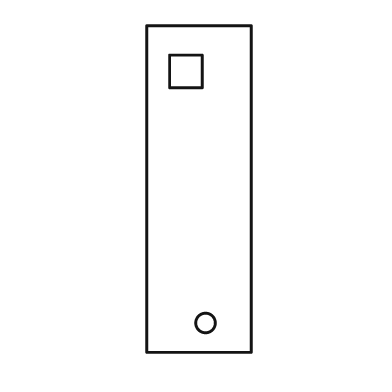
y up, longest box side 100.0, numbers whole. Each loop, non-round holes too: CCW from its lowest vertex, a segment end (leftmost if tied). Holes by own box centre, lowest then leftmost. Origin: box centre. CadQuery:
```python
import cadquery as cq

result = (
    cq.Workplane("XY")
    .moveTo(-16.0, -50.0)
    .lineTo(16.0, -50.0)
    .lineTo(16.0, 50.0)
    .lineTo(-16.0, 50.0)
    .close()
    .moveTo(2.0, -41.0)
    .circle(3.0)
    .moveTo(-9.0, 31.0)
    .lineTo(1.0, 31.0)
    .lineTo(1.0, 41.0)
    .lineTo(-9.0, 41.0)
    .close()
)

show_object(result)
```